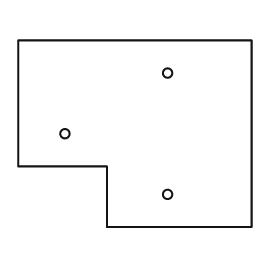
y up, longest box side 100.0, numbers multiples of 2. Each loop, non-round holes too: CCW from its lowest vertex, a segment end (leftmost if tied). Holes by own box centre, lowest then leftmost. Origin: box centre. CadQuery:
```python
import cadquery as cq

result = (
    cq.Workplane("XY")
    .moveTo(-12.0, -40.0)
    .lineTo(50.0, -40.0)
    .lineTo(50.0, 40.0)
    .lineTo(-50.0, 40.0)
    .lineTo(-50.0, -14.0)
    .lineTo(-12.0, -14.0)
    .close()
    .moveTo(14.0, -26.0)
    .circle(2.0)
    .moveTo(-30.0, 0.0)
    .circle(2.0)
    .moveTo(14.0, 26.0)
    .circle(2.0)
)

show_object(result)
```